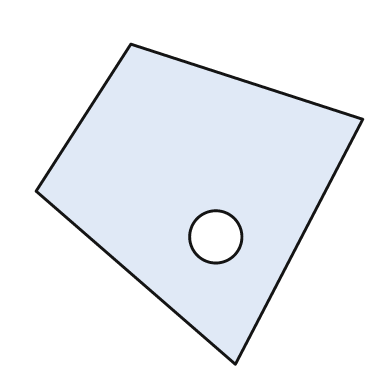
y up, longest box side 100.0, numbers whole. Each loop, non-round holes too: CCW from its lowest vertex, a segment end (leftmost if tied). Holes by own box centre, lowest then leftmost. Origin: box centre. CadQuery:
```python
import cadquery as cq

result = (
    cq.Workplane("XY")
    .moveTo(11.0, -49.0)
    .lineTo(50.0, 26.0)
    .lineTo(-21.0, 49.0)
    .lineTo(-50.0, 4.0)
    .close()
    .moveTo(5.0, -10.0)
    .circle(8.0)
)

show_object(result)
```